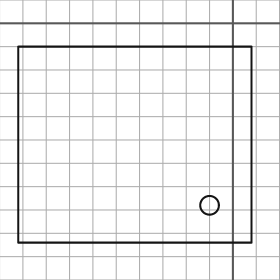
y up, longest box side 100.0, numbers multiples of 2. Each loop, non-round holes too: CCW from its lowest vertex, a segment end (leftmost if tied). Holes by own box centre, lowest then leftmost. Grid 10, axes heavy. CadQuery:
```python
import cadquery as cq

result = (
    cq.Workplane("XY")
    .moveTo(-92.0, -94.0)
    .lineTo(8.0, -94.0)
    .lineTo(8.0, -10.0)
    .lineTo(-92.0, -10.0)
    .close()
    .moveTo(-10.0, -78.0)
    .circle(4.0)
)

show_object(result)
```